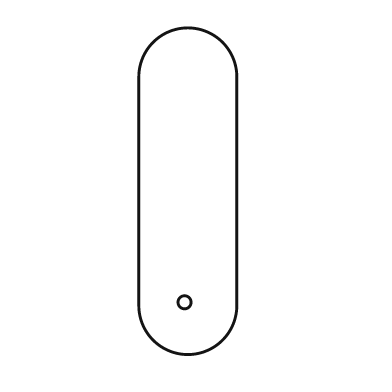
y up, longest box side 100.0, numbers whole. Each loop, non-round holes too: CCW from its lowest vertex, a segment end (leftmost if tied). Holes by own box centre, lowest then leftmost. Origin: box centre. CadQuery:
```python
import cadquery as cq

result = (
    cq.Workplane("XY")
    .moveTo(-15.0, -35.0)
    .threePointArc((0.0, -50.0), (15.0, -35.0))
    .lineTo(15.0, 35.0)
    .threePointArc((0.0, 50.0), (-15.0, 35.0))
    .close()
    .moveTo(-1.0, -34.0)
    .circle(2.0)
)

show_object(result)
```